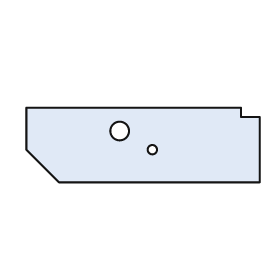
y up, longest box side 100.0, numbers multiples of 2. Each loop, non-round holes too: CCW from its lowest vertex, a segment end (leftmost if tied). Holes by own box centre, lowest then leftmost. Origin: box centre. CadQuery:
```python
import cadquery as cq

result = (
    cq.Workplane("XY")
    .moveTo(-36.0, -16.0)
    .lineTo(50.0, -16.0)
    .lineTo(50.0, 12.0)
    .lineTo(42.0, 12.0)
    .lineTo(42.0, 16.0)
    .lineTo(-50.0, 16.0)
    .lineTo(-50.0, -2.0)
    .close()
    .moveTo(4.0, -2.0)
    .circle(2.0)
    .moveTo(-10.0, 6.0)
    .circle(4.0)
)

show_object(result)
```